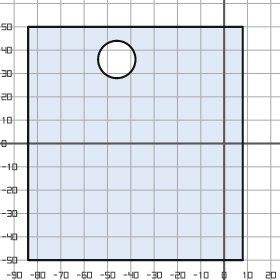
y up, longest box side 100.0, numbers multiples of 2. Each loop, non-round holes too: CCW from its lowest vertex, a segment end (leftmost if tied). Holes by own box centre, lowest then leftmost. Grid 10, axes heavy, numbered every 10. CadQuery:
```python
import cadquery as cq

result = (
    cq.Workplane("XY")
    .moveTo(-84.0, -50.0)
    .lineTo(8.0, -50.0)
    .lineTo(8.0, 50.0)
    .lineTo(-84.0, 50.0)
    .close()
    .moveTo(-46.0, 36.0)
    .circle(8.0)
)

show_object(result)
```